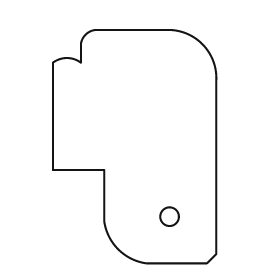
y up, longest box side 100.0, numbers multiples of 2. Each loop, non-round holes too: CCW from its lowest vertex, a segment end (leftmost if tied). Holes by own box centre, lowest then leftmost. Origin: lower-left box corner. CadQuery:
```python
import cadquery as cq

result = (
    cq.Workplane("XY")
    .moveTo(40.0, 0.0)
    .lineTo(66.0, 0.0)
    .lineTo(70.0, 4.0)
    .lineTo(70.0, 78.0)
    .threePointArc((64.0, 94.0), (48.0, 100.0))
    .lineTo(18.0, 100.0)
    .threePointArc((14.0, 98.0), (12.0, 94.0))
    .lineTo(12.0, 86.0)
    .threePointArc((6.0, 88.0), (0.0, 86.0))
    .lineTo(0.0, 40.0)
    .lineTo(22.0, 40.0)
    .lineTo(22.0, 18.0)
    .threePointArc((28.0, 6.0), (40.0, 0.0))
    .close()
    .moveTo(50.0, 20.0)
    .circle(4.0)
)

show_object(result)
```